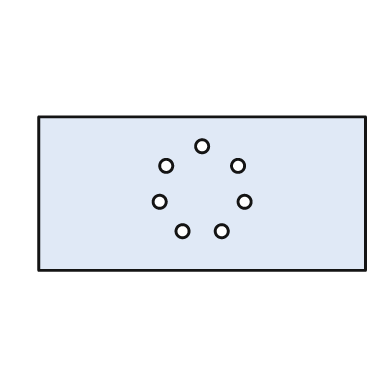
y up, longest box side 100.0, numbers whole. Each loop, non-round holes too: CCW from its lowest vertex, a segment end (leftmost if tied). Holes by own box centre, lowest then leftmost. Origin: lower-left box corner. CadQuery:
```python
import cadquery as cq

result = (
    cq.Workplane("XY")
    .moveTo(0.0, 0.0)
    .lineTo(100.0, 0.0)
    .lineTo(100.0, 47.0)
    .lineTo(0.0, 47.0)
    .close()
    .moveTo(44.0, 12.0)
    .circle(2.0)
    .moveTo(56.0, 12.0)
    .circle(2.0)
    .moveTo(37.0, 21.0)
    .circle(2.0)
    .moveTo(63.0, 21.0)
    .circle(2.0)
    .moveTo(39.0, 32.0)
    .circle(2.0)
    .moveTo(61.0, 32.0)
    .circle(2.0)
    .moveTo(50.0, 38.0)
    .circle(2.0)
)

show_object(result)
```